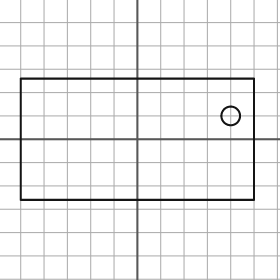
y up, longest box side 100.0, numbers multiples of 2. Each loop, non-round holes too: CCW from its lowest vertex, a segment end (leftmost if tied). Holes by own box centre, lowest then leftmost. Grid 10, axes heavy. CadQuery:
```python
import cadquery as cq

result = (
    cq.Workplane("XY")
    .moveTo(-50.0, -26.0)
    .lineTo(50.0, -26.0)
    .lineTo(50.0, 26.0)
    .lineTo(-50.0, 26.0)
    .close()
    .moveTo(40.0, 10.0)
    .circle(4.0)
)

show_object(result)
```